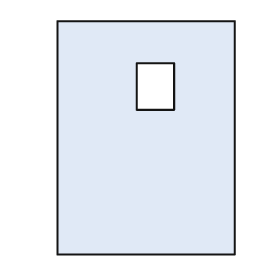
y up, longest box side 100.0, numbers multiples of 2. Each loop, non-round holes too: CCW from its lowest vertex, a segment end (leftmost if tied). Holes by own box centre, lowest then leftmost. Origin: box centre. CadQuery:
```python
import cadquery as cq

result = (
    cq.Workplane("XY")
    .moveTo(-38.0, -50.0)
    .lineTo(38.0, -50.0)
    .lineTo(38.0, 50.0)
    .lineTo(-38.0, 50.0)
    .close()
    .moveTo(-4.0, 12.0)
    .lineTo(12.0, 12.0)
    .lineTo(12.0, 32.0)
    .lineTo(-4.0, 32.0)
    .close()
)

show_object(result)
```